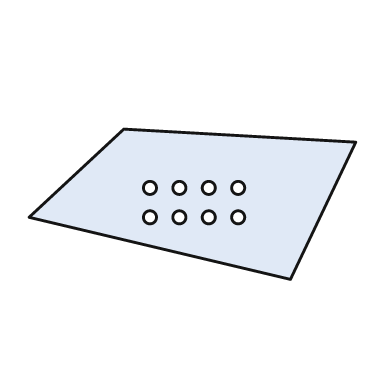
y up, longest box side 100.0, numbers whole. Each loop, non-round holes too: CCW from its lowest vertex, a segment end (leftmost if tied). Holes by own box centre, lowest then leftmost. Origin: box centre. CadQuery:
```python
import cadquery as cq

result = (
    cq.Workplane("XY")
    .moveTo(30.0, -23.0)
    .lineTo(50.0, 19.0)
    .lineTo(-21.0, 23.0)
    .lineTo(-50.0, -4.0)
    .close()
    .moveTo(-13.0, -4.0)
    .circle(2.0)
    .moveTo(-4.0, -4.0)
    .circle(2.0)
    .moveTo(5.0, -4.0)
    .circle(2.0)
    .moveTo(14.0, -4.0)
    .circle(2.0)
    .moveTo(-13.0, 5.0)
    .circle(2.0)
    .moveTo(-4.0, 5.0)
    .circle(2.0)
    .moveTo(5.0, 5.0)
    .circle(2.0)
    .moveTo(14.0, 5.0)
    .circle(2.0)
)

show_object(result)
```